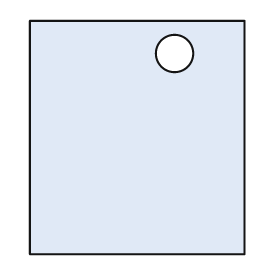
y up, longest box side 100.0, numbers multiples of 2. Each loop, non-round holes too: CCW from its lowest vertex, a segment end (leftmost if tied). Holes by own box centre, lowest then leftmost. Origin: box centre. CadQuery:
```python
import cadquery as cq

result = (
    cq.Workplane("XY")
    .moveTo(-46.0, -50.0)
    .lineTo(46.0, -50.0)
    .lineTo(46.0, 50.0)
    .lineTo(-46.0, 50.0)
    .close()
    .moveTo(16.0, 36.0)
    .circle(8.0)
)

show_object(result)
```